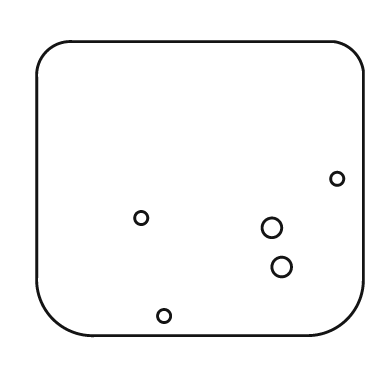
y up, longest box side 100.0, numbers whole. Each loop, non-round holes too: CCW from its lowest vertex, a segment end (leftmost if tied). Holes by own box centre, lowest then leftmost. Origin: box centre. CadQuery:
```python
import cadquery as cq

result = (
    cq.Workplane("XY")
    .moveTo(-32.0, -45.0)
    .lineTo(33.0, -45.0)
    .threePointArc((45.0, -40.0), (50.0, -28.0))
    .lineTo(50.0, 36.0)
    .threePointArc((47.0, 42.0), (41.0, 45.0))
    .lineTo(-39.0, 45.0)
    .threePointArc((-47.0, 42.0), (-50.0, 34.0))
    .lineTo(-50.0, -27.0)
    .threePointArc((-45.0, -40.0), (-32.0, -45.0))
    .close()
    .moveTo(-11.0, -39.0)
    .circle(2.0)
    .moveTo(25.0, -24.0)
    .circle(3.0)
    .moveTo(22.0, -12.0)
    .circle(3.0)
    .moveTo(-18.0, -9.0)
    .circle(2.0)
    .moveTo(42.0, 3.0)
    .circle(2.0)
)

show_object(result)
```